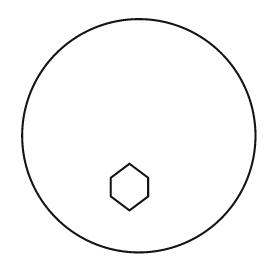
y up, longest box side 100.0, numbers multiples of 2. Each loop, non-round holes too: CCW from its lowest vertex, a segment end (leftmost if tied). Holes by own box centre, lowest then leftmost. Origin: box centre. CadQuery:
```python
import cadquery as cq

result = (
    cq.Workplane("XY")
    .moveTo(0.0, 0.0)
    .circle(50.0)
    .moveTo(-4.0, -32.0)
    .lineTo(4.0, -26.0)
    .lineTo(4.0, -18.0)
    .lineTo(-4.0, -12.0)
    .lineTo(-12.0, -18.0)
    .lineTo(-12.0, -26.0)
    .close()
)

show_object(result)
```